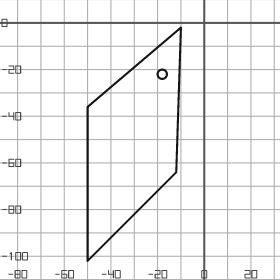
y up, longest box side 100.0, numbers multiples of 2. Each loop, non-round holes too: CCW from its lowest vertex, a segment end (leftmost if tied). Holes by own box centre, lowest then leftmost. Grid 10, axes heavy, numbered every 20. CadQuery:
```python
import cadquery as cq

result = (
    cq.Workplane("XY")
    .moveTo(-50.0, -102.0)
    .lineTo(-12.0, -64.0)
    .lineTo(-10.0, -2.0)
    .lineTo(-50.0, -36.0)
    .close()
    .moveTo(-18.0, -22.0)
    .circle(2.0)
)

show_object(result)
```